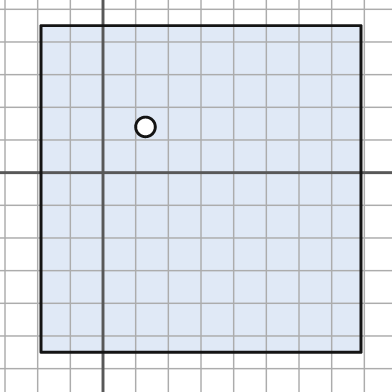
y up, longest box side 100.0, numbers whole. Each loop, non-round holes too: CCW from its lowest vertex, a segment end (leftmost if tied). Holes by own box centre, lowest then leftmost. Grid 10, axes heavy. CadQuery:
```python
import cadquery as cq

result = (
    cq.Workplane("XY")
    .moveTo(-19.0, -55.0)
    .lineTo(79.0, -55.0)
    .lineTo(79.0, 45.0)
    .lineTo(-19.0, 45.0)
    .close()
    .moveTo(13.0, 14.0)
    .circle(3.0)
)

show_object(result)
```